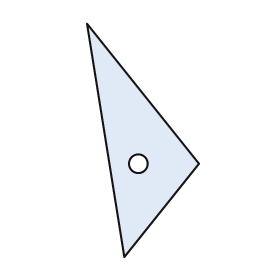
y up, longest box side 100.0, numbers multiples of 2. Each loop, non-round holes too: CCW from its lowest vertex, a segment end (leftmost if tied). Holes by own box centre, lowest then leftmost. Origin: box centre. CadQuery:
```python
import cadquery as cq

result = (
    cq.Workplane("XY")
    .moveTo(-8.0, -50.0)
    .lineTo(24.0, -10.0)
    .lineTo(-24.0, 50.0)
    .close()
    .moveTo(-2.0, -10.0)
    .circle(4.0)
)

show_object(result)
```